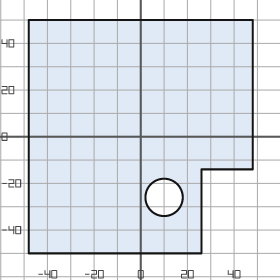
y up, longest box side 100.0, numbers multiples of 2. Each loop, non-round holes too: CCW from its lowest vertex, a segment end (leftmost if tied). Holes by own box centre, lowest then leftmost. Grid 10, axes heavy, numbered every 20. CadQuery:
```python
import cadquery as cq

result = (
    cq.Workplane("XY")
    .moveTo(-48.0, -50.0)
    .lineTo(26.0, -50.0)
    .lineTo(26.0, -14.0)
    .lineTo(48.0, -14.0)
    .lineTo(48.0, 50.0)
    .lineTo(-48.0, 50.0)
    .close()
    .moveTo(10.0, -26.0)
    .circle(8.0)
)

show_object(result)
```